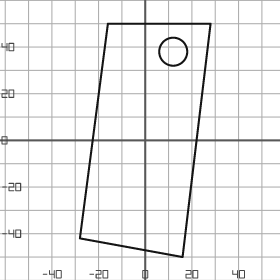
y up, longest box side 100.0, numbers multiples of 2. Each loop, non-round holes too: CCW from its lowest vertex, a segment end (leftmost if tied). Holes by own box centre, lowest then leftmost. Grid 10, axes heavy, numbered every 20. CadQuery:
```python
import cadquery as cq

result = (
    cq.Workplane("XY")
    .moveTo(16.0, -50.0)
    .lineTo(28.0, 50.0)
    .lineTo(-16.0, 50.0)
    .lineTo(-28.0, -42.0)
    .close()
    .moveTo(12.0, 38.0)
    .circle(6.0)
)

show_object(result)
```